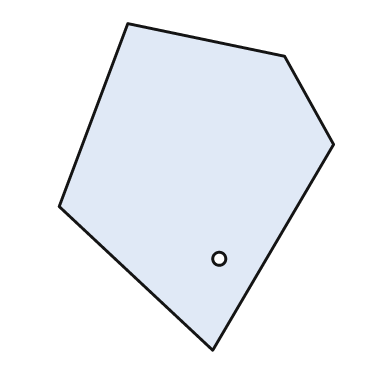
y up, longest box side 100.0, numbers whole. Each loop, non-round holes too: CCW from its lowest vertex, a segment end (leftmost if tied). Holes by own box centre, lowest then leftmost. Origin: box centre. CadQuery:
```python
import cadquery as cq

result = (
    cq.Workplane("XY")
    .moveTo(5.0, -50.0)
    .lineTo(42.0, 13.0)
    .lineTo(27.0, 40.0)
    .lineTo(-21.0, 50.0)
    .lineTo(-42.0, -6.0)
    .close()
    .moveTo(7.0, -22.0)
    .circle(2.0)
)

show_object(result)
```